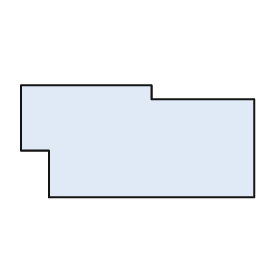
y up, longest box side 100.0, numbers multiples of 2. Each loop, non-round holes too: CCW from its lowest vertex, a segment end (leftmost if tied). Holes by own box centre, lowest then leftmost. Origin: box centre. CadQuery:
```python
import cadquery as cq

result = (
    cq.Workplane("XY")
    .moveTo(-38.0, -24.0)
    .lineTo(50.0, -24.0)
    .lineTo(50.0, 18.0)
    .lineTo(6.0, 18.0)
    .lineTo(6.0, 24.0)
    .lineTo(-50.0, 24.0)
    .lineTo(-50.0, -4.0)
    .lineTo(-38.0, -4.0)
    .close()
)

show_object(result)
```